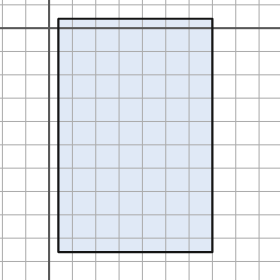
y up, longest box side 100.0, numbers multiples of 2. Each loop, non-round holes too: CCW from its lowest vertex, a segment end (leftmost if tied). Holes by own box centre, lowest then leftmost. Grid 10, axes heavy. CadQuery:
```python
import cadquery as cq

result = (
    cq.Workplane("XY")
    .moveTo(4.0, -96.0)
    .lineTo(70.0, -96.0)
    .lineTo(70.0, 4.0)
    .lineTo(4.0, 4.0)
    .close()
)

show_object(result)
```